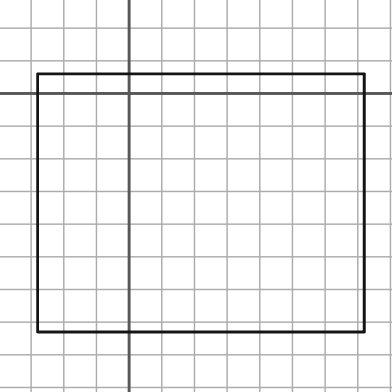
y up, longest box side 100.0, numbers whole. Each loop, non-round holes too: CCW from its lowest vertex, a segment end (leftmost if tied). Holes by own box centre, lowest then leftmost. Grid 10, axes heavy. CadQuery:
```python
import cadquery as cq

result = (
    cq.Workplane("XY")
    .moveTo(-28.0, -73.0)
    .lineTo(72.0, -73.0)
    .lineTo(72.0, 6.0)
    .lineTo(-28.0, 6.0)
    .close()
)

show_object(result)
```